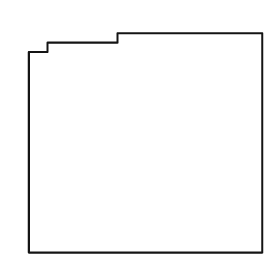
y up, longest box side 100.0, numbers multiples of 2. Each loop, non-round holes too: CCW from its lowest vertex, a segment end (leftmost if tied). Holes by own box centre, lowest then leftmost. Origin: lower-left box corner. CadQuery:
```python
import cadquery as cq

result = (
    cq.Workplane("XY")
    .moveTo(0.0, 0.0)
    .lineTo(100.0, 0.0)
    .lineTo(100.0, 94.0)
    .lineTo(38.0, 94.0)
    .lineTo(38.0, 90.0)
    .lineTo(8.0, 90.0)
    .lineTo(8.0, 86.0)
    .lineTo(0.0, 86.0)
    .close()
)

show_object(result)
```